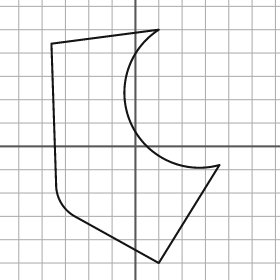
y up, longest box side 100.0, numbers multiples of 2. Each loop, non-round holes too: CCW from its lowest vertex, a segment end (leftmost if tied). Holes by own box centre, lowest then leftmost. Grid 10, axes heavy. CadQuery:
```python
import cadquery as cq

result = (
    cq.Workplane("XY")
    .moveTo(10.0, -50.0)
    .lineTo(36.0, -8.0)
    .threePointArc((-2.0, 10.0), (10.0, 50.0))
    .lineTo(-36.0, 44.0)
    .lineTo(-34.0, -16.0)
    .threePointArc((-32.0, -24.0), (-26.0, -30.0))
    .close()
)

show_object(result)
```